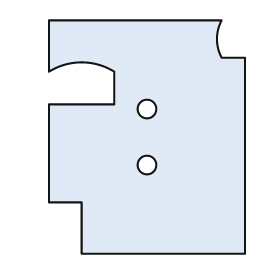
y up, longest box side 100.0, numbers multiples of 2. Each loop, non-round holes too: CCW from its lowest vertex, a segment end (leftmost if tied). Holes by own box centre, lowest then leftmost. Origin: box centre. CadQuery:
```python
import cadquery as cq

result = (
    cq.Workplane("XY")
    .moveTo(-28.0, -50.0)
    .lineTo(42.0, -50.0)
    .lineTo(42.0, 34.0)
    .lineTo(32.0, 34.0)
    .threePointArc((30.0, 42.0), (32.0, 50.0))
    .lineTo(-42.0, 50.0)
    .lineTo(-42.0, 28.0)
    .threePointArc((-28.0, 32.0), (-14.0, 28.0))
    .lineTo(-14.0, 14.0)
    .lineTo(-42.0, 14.0)
    .lineTo(-42.0, -28.0)
    .lineTo(-28.0, -28.0)
    .close()
    .moveTo(0.0, -12.0)
    .circle(4.0)
    .moveTo(0.0, 12.0)
    .circle(4.0)
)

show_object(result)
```